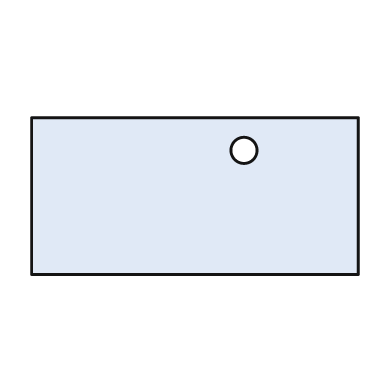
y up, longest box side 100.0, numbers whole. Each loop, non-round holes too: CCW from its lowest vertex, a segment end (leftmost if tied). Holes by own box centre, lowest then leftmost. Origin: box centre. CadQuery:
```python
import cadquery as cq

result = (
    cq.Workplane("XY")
    .moveTo(-50.0, -24.0)
    .lineTo(50.0, -24.0)
    .lineTo(50.0, 24.0)
    .lineTo(-50.0, 24.0)
    .close()
    .moveTo(15.0, 14.0)
    .circle(4.0)
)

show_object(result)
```